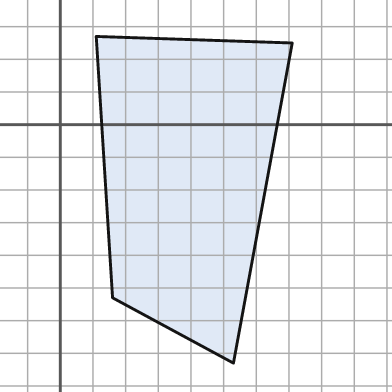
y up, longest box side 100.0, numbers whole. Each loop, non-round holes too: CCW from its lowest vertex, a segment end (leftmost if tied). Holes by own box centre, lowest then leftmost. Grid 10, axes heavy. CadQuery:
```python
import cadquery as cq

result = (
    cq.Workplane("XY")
    .moveTo(53.0, -73.0)
    .lineTo(71.0, 25.0)
    .lineTo(11.0, 27.0)
    .lineTo(16.0, -53.0)
    .close()
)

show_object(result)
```